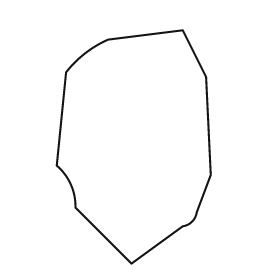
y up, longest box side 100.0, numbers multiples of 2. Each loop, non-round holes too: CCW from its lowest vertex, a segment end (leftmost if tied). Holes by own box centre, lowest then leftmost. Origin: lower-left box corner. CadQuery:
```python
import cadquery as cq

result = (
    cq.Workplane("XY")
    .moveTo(32.0, 0.0)
    .lineTo(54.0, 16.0)
    .threePointArc((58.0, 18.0), (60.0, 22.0))
    .lineTo(66.0, 38.0)
    .lineTo(64.0, 80.0)
    .lineTo(54.0, 100.0)
    .lineTo(22.0, 96.0)
    .threePointArc((12.0, 90.0), (4.0, 82.0))
    .lineTo(0.0, 42.0)
    .threePointArc((6.0, 34.0), (8.0, 24.0))
    .close()
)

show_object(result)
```